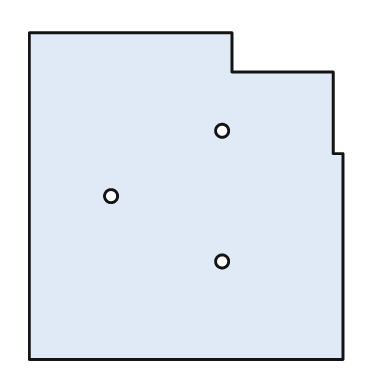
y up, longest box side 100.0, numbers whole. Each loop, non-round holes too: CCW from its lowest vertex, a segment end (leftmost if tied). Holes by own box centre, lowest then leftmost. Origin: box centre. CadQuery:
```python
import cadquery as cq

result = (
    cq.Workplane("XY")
    .moveTo(-48.0, -50.0)
    .lineTo(48.0, -50.0)
    .lineTo(48.0, 13.0)
    .lineTo(45.0, 13.0)
    .lineTo(45.0, 38.0)
    .lineTo(14.0, 38.0)
    .lineTo(14.0, 50.0)
    .lineTo(-48.0, 50.0)
    .close()
    .moveTo(11.0, -20.0)
    .circle(2.0)
    .moveTo(-23.0, 0.0)
    .circle(2.0)
    .moveTo(11.0, 20.0)
    .circle(2.0)
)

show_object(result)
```